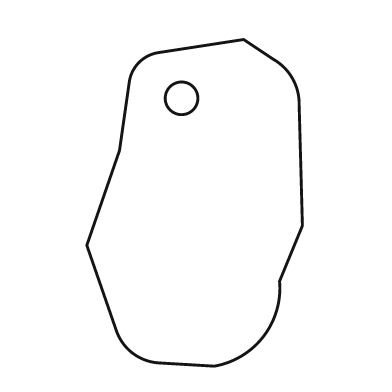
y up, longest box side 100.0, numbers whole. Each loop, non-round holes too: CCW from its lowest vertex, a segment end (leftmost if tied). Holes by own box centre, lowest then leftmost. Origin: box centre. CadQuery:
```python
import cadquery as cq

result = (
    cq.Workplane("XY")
    .moveTo(6.0, -50.0)
    .threePointArc((21.0, -41.0), (26.0, -24.0))
    .lineTo(33.0, -7.0)
    .lineTo(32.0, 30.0)
    .threePointArc((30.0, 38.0), (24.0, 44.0))
    .lineTo(15.0, 50.0)
    .lineTo(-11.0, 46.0)
    .threePointArc((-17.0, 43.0), (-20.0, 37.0))
    .lineTo(-23.0, 16.0)
    .lineTo(-33.0, -13.0)
    .lineTo(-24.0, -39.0)
    .threePointArc((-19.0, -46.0), (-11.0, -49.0))
    .close()
    .moveTo(-4.0, 32.0)
    .circle(5.0)
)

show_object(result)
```